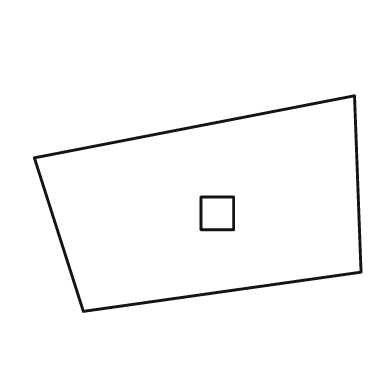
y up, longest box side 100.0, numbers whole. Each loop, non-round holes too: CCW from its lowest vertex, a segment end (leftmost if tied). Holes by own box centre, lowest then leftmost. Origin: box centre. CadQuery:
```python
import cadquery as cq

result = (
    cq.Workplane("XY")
    .moveTo(-35.0, -33.0)
    .lineTo(50.0, -21.0)
    .lineTo(48.0, 33.0)
    .lineTo(-50.0, 14.0)
    .close()
    .moveTo(1.0, -8.0)
    .lineTo(11.0, -8.0)
    .lineTo(11.0, 2.0)
    .lineTo(1.0, 2.0)
    .close()
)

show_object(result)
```